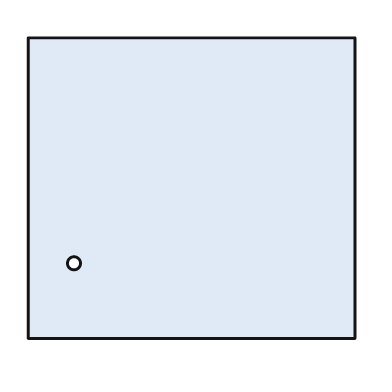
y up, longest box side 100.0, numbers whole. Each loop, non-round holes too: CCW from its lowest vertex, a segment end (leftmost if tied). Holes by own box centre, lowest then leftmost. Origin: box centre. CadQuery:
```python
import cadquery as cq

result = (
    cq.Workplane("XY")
    .moveTo(-50.0, -46.0)
    .lineTo(50.0, -46.0)
    .lineTo(50.0, 46.0)
    .lineTo(-50.0, 46.0)
    .close()
    .moveTo(-36.0, -23.0)
    .circle(2.0)
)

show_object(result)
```